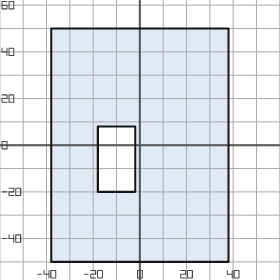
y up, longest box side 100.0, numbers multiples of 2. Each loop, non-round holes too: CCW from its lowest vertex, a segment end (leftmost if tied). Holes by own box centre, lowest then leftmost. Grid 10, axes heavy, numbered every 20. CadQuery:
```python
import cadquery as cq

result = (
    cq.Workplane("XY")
    .moveTo(-38.0, -50.0)
    .lineTo(38.0, -50.0)
    .lineTo(38.0, 50.0)
    .lineTo(-38.0, 50.0)
    .close()
    .moveTo(-18.0, -20.0)
    .lineTo(-2.0, -20.0)
    .lineTo(-2.0, 8.0)
    .lineTo(-18.0, 8.0)
    .close()
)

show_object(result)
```